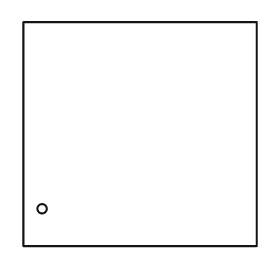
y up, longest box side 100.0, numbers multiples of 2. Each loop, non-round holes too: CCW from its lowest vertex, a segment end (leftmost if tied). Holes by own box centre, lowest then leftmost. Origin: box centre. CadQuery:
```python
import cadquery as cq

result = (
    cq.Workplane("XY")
    .moveTo(-50.0, -48.0)
    .lineTo(50.0, -48.0)
    .lineTo(50.0, 48.0)
    .lineTo(-50.0, 48.0)
    .close()
    .moveTo(-42.0, -32.0)
    .circle(2.0)
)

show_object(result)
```